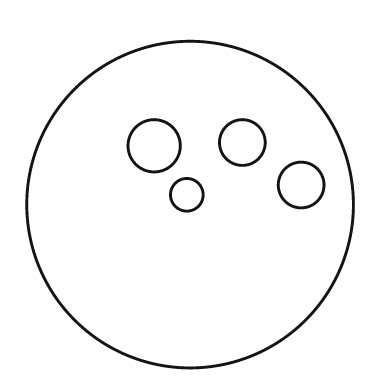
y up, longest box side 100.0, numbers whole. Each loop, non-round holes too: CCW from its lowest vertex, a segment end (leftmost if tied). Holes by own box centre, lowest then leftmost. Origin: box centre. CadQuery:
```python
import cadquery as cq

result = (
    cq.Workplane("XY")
    .moveTo(0.0, 0.0)
    .circle(50.0)
    .moveTo(-1.0, 3.0)
    .circle(5.0)
    .moveTo(34.0, 6.0)
    .circle(7.0)
    .moveTo(-11.0, 18.0)
    .circle(8.0)
    .moveTo(16.0, 19.0)
    .circle(7.0)
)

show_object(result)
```